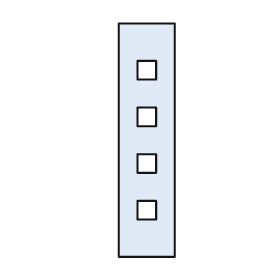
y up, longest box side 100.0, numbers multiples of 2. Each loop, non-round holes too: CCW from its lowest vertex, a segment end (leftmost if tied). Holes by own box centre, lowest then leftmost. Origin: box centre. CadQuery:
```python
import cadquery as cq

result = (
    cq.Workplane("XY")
    .moveTo(-12.0, -50.0)
    .lineTo(12.0, -50.0)
    .lineTo(12.0, 50.0)
    .lineTo(-12.0, 50.0)
    .close()
    .moveTo(-4.0, -34.0)
    .lineTo(4.0, -34.0)
    .lineTo(4.0, -26.0)
    .lineTo(-4.0, -26.0)
    .close()
    .moveTo(-4.0, -14.0)
    .lineTo(4.0, -14.0)
    .lineTo(4.0, -6.0)
    .lineTo(-4.0, -6.0)
    .close()
    .moveTo(-4.0, 6.0)
    .lineTo(4.0, 6.0)
    .lineTo(4.0, 14.0)
    .lineTo(-4.0, 14.0)
    .close()
    .moveTo(-4.0, 26.0)
    .lineTo(4.0, 26.0)
    .lineTo(4.0, 34.0)
    .lineTo(-4.0, 34.0)
    .close()
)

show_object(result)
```